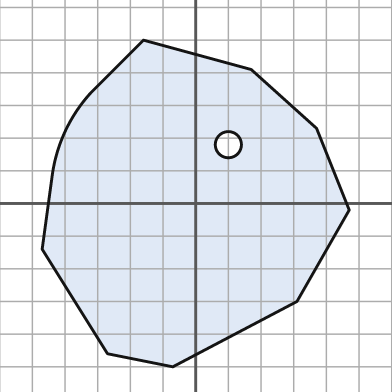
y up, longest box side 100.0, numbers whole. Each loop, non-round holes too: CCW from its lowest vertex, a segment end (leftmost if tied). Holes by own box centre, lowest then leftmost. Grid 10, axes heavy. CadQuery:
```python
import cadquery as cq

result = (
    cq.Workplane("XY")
    .moveTo(-7.0, -50.0)
    .lineTo(31.0, -30.0)
    .lineTo(47.0, -2.0)
    .lineTo(37.0, 23.0)
    .lineTo(17.0, 41.0)
    .lineTo(-16.0, 50.0)
    .lineTo(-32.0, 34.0)
    .threePointArc((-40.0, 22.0), (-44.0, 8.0))
    .lineTo(-47.0, -14.0)
    .lineTo(-27.0, -46.0)
    .close()
    .moveTo(10.0, 18.0)
    .circle(4.0)
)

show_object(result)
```